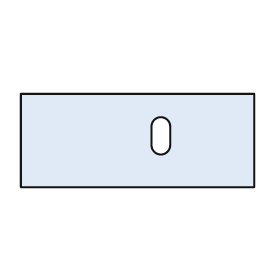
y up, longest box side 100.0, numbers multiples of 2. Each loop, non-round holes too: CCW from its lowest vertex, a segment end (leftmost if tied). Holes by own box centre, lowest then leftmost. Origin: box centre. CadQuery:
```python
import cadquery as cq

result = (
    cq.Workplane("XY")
    .moveTo(-50.0, -20.0)
    .lineTo(50.0, -20.0)
    .lineTo(50.0, 20.0)
    .lineTo(-50.0, 20.0)
    .close()
    .moveTo(6.0, -2.0)
    .threePointArc((10.0, -6.0), (14.0, -2.0))
    .lineTo(14.0, 6.0)
    .threePointArc((10.0, 10.0), (6.0, 6.0))
    .close()
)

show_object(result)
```